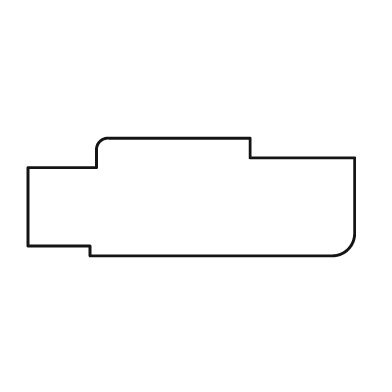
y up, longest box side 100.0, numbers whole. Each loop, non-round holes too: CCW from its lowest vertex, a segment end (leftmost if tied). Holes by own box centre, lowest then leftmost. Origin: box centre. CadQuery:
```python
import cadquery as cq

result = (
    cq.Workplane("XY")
    .moveTo(-31.0, -18.0)
    .lineTo(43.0, -18.0)
    .threePointArc((48.0, -16.0), (50.0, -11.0))
    .lineTo(50.0, 12.0)
    .lineTo(18.0, 12.0)
    .lineTo(18.0, 18.0)
    .lineTo(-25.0, 18.0)
    .threePointArc((-28.0, 17.0), (-29.0, 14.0))
    .lineTo(-29.0, 9.0)
    .lineTo(-50.0, 9.0)
    .lineTo(-50.0, -15.0)
    .lineTo(-31.0, -15.0)
    .close()
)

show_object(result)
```